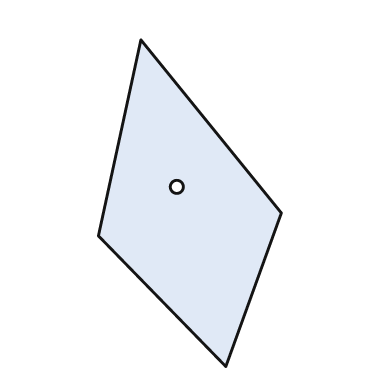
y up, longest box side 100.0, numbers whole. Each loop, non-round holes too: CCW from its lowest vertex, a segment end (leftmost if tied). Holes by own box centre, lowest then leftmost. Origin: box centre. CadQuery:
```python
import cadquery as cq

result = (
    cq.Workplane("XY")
    .moveTo(11.0, -50.0)
    .lineTo(28.0, -3.0)
    .lineTo(-15.0, 50.0)
    .lineTo(-28.0, -10.0)
    .close()
    .moveTo(-4.0, 5.0)
    .circle(2.0)
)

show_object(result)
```